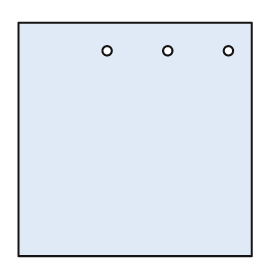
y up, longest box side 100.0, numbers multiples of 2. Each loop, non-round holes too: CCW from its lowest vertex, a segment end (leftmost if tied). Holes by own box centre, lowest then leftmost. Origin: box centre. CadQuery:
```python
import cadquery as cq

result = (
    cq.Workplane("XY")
    .moveTo(-50.0, -50.0)
    .lineTo(50.0, -50.0)
    .lineTo(50.0, 50.0)
    .lineTo(-50.0, 50.0)
    .close()
    .moveTo(-12.0, 38.0)
    .circle(2.0)
    .moveTo(14.0, 38.0)
    .circle(2.0)
    .moveTo(40.0, 38.0)
    .circle(2.0)
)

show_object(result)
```